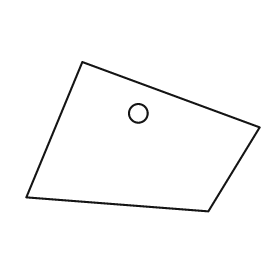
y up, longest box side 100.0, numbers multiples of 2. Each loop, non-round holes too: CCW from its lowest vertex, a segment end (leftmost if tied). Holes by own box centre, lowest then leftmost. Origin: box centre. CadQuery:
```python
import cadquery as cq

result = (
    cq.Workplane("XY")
    .moveTo(28.0, -32.0)
    .lineTo(50.0, 4.0)
    .lineTo(-26.0, 32.0)
    .lineTo(-50.0, -26.0)
    .close()
    .moveTo(-2.0, 10.0)
    .circle(4.0)
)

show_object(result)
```